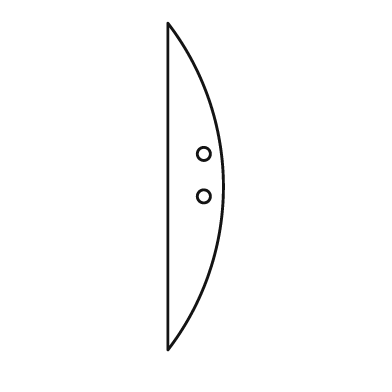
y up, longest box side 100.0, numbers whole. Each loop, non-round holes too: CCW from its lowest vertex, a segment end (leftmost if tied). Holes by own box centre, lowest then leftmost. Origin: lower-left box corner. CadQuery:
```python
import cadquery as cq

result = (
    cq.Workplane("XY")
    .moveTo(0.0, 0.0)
    .threePointArc((17.0, 50.0), (0.0, 100.0))
    .close()
    .moveTo(11.0, 47.0)
    .circle(2.0)
    .moveTo(11.0, 60.0)
    .circle(2.0)
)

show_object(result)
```